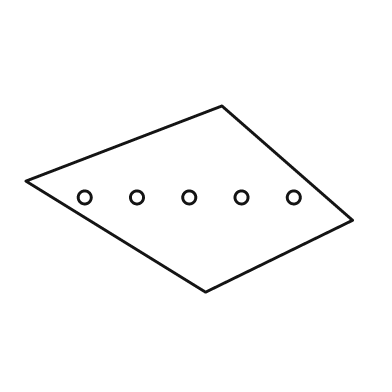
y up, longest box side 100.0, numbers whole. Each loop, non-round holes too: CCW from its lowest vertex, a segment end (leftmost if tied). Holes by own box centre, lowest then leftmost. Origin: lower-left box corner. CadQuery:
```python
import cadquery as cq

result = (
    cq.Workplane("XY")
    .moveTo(55.0, 0.0)
    .lineTo(100.0, 22.0)
    .lineTo(60.0, 57.0)
    .lineTo(0.0, 34.0)
    .close()
    .moveTo(18.0, 29.0)
    .circle(2.0)
    .moveTo(34.0, 29.0)
    .circle(2.0)
    .moveTo(50.0, 29.0)
    .circle(2.0)
    .moveTo(66.0, 29.0)
    .circle(2.0)
    .moveTo(82.0, 29.0)
    .circle(2.0)
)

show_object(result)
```